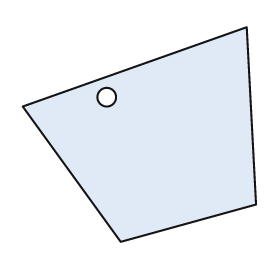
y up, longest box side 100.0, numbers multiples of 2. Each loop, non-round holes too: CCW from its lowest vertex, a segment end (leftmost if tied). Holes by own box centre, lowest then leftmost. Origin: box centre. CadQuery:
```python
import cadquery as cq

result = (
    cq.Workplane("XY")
    .moveTo(-8.0, -46.0)
    .lineTo(50.0, -30.0)
    .lineTo(46.0, 46.0)
    .lineTo(-50.0, 12.0)
    .close()
    .moveTo(-14.0, 16.0)
    .circle(4.0)
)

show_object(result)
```